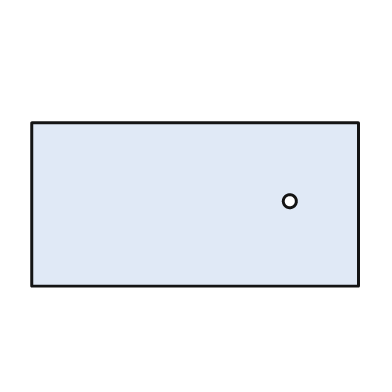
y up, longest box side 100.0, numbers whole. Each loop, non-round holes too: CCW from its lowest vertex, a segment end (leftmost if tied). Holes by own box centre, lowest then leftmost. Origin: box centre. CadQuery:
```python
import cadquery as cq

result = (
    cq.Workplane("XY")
    .moveTo(-50.0, -25.0)
    .lineTo(50.0, -25.0)
    .lineTo(50.0, 25.0)
    .lineTo(-50.0, 25.0)
    .close()
    .moveTo(29.0, 1.0)
    .circle(2.0)
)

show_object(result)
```